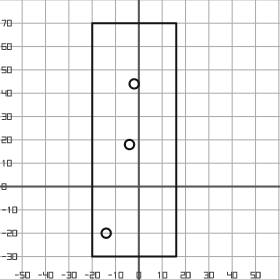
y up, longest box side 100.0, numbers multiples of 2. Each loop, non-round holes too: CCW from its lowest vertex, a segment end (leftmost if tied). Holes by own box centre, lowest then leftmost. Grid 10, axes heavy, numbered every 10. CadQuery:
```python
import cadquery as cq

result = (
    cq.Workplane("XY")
    .moveTo(-20.0, -30.0)
    .lineTo(16.0, -30.0)
    .lineTo(16.0, 70.0)
    .lineTo(-20.0, 70.0)
    .close()
    .moveTo(-14.0, -20.0)
    .circle(2.0)
    .moveTo(-4.0, 18.0)
    .circle(2.0)
    .moveTo(-2.0, 44.0)
    .circle(2.0)
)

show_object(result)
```